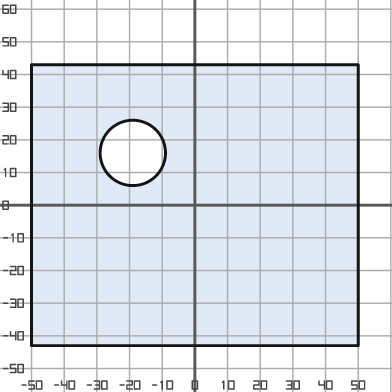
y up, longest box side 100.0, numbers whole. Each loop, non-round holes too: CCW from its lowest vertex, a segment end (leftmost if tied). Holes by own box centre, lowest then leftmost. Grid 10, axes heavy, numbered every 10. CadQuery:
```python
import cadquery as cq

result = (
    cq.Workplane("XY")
    .moveTo(-50.0, -43.0)
    .lineTo(50.0, -43.0)
    .lineTo(50.0, 43.0)
    .lineTo(-50.0, 43.0)
    .close()
    .moveTo(-19.0, 16.0)
    .circle(10.0)
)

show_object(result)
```